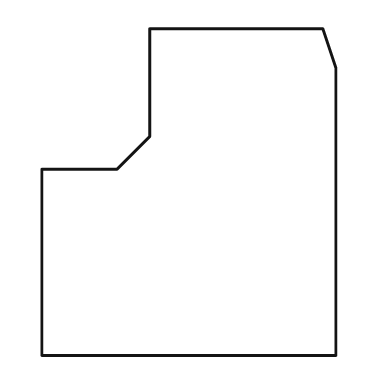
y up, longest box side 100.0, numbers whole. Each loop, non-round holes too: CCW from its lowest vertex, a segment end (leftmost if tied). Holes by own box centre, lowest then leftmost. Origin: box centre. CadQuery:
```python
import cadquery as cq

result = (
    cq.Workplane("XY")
    .moveTo(-45.0, -50.0)
    .lineTo(45.0, -50.0)
    .lineTo(45.0, 38.0)
    .lineTo(41.0, 50.0)
    .lineTo(-12.0, 50.0)
    .lineTo(-12.0, 17.0)
    .lineTo(-22.0, 7.0)
    .lineTo(-45.0, 7.0)
    .close()
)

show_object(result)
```